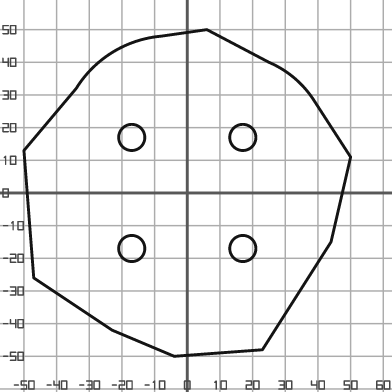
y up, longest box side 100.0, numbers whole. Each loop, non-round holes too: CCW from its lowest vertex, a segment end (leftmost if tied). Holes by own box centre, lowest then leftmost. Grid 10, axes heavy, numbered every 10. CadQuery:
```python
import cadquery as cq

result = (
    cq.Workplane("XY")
    .moveTo(-4.0, -50.0)
    .lineTo(23.0, -48.0)
    .lineTo(44.0, -15.0)
    .lineTo(50.0, 11.0)
    .lineTo(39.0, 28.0)
    .threePointArc((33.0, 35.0), (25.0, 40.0))
    .lineTo(6.0, 50.0)
    .lineTo(-8.0, 48.0)
    .threePointArc((-23.0, 43.0), (-34.0, 32.0))
    .lineTo(-50.0, 13.0)
    .lineTo(-47.0, -26.0)
    .lineTo(-23.0, -42.0)
    .close()
    .moveTo(-17.0, -17.0)
    .circle(4.0)
    .moveTo(17.0, -17.0)
    .circle(4.0)
    .moveTo(-17.0, 17.0)
    .circle(4.0)
    .moveTo(17.0, 17.0)
    .circle(4.0)
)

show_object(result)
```